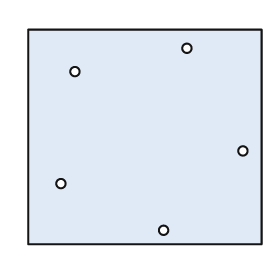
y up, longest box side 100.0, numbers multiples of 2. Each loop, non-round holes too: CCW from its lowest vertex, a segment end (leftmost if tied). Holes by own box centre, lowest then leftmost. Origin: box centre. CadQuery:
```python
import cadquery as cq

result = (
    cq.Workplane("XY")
    .moveTo(-50.0, -46.0)
    .lineTo(50.0, -46.0)
    .lineTo(50.0, 46.0)
    .lineTo(-50.0, 46.0)
    .close()
    .moveTo(8.0, -40.0)
    .circle(2.0)
    .moveTo(-36.0, -20.0)
    .circle(2.0)
    .moveTo(42.0, -6.0)
    .circle(2.0)
    .moveTo(-30.0, 28.0)
    .circle(2.0)
    .moveTo(18.0, 38.0)
    .circle(2.0)
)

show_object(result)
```